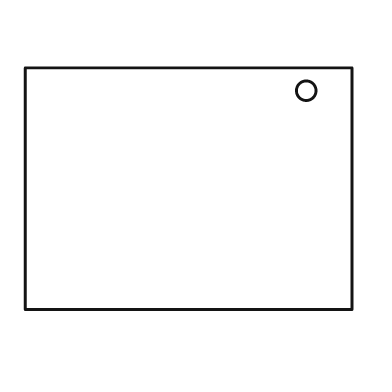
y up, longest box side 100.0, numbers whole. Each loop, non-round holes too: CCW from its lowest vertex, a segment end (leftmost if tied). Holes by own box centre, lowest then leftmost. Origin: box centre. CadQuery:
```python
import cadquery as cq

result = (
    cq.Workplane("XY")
    .moveTo(-50.0, -37.0)
    .lineTo(50.0, -37.0)
    .lineTo(50.0, 37.0)
    .lineTo(-50.0, 37.0)
    .close()
    .moveTo(36.0, 30.0)
    .circle(3.0)
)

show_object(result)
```